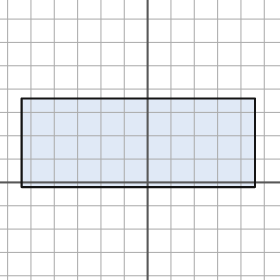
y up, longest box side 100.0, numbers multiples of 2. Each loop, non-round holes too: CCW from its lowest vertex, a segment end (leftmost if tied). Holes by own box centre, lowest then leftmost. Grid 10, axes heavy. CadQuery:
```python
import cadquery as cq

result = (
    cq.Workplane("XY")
    .moveTo(-54.0, -2.0)
    .lineTo(46.0, -2.0)
    .lineTo(46.0, 36.0)
    .lineTo(-54.0, 36.0)
    .close()
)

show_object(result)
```